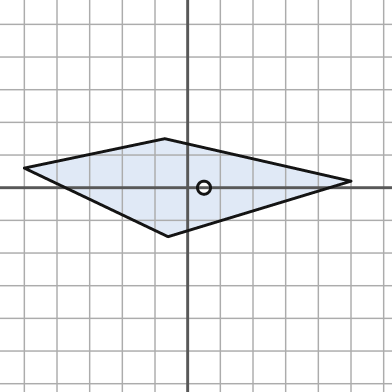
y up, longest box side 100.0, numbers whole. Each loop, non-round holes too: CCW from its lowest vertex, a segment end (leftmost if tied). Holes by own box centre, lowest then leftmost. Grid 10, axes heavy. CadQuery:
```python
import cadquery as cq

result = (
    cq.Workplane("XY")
    .moveTo(-6.0, -15.0)
    .lineTo(50.0, 2.0)
    .lineTo(-7.0, 15.0)
    .lineTo(-50.0, 6.0)
    .close()
    .moveTo(5.0, 0.0)
    .circle(2.0)
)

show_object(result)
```